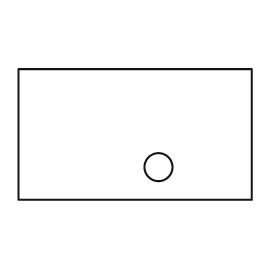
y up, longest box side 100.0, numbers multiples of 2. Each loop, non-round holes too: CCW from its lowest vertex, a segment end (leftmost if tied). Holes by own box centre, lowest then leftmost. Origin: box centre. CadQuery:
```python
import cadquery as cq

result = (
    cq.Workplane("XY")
    .moveTo(-50.0, -28.0)
    .lineTo(50.0, -28.0)
    .lineTo(50.0, 28.0)
    .lineTo(-50.0, 28.0)
    .close()
    .moveTo(10.0, -14.0)
    .circle(6.0)
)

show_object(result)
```